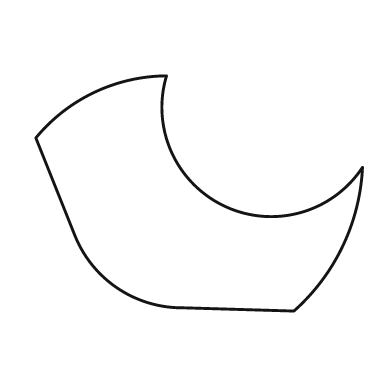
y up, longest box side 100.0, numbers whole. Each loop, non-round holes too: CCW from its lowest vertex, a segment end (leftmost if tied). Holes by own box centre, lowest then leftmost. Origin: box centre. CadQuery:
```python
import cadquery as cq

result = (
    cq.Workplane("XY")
    .moveTo(29.0, -36.0)
    .threePointArc((44.0, -16.0), (50.0, 8.0))
    .threePointArc((8.0, -4.0), (-10.0, 36.0))
    .threePointArc((-32.0, 31.0), (-50.0, 17.0))
    .lineTo(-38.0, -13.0)
    .threePointArc((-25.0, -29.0), (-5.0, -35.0))
    .close()
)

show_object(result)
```